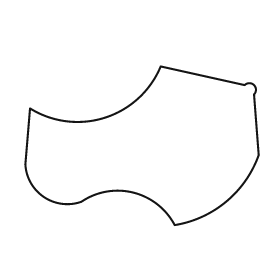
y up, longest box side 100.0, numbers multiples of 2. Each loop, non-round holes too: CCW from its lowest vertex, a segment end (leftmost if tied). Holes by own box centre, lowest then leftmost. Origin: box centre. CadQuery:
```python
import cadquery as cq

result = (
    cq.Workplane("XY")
    .moveTo(14.0, -34.0)
    .threePointArc((36.0, -24.0), (50.0, -4.0))
    .lineTo(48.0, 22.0)
    .threePointArc((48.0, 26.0), (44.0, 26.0))
    .lineTo(8.0, 34.0)
    .threePointArc((-16.0, 12.0), (-48.0, 16.0))
    .lineTo(-50.0, -8.0)
    .threePointArc((-42.0, -22.0), (-26.0, -24.0))
    .threePointArc((-4.0, -20.0), (14.0, -34.0))
    .close()
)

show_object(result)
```